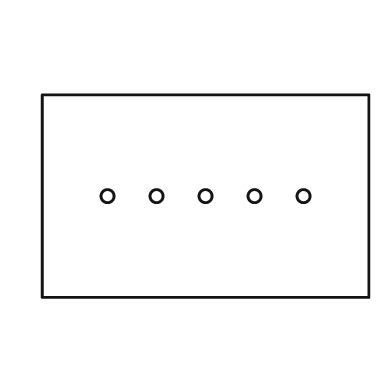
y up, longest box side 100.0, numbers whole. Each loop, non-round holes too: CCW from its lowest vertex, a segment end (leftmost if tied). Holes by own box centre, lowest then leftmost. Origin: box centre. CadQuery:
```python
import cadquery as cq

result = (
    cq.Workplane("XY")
    .moveTo(-50.0, -31.0)
    .lineTo(50.0, -31.0)
    .lineTo(50.0, 31.0)
    .lineTo(-50.0, 31.0)
    .close()
    .moveTo(-30.0, 0.0)
    .circle(2.0)
    .moveTo(-15.0, 0.0)
    .circle(2.0)
    .moveTo(0.0, 0.0)
    .circle(2.0)
    .moveTo(15.0, 0.0)
    .circle(2.0)
    .moveTo(30.0, 0.0)
    .circle(2.0)
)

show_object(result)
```